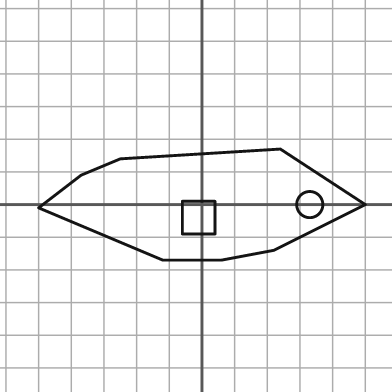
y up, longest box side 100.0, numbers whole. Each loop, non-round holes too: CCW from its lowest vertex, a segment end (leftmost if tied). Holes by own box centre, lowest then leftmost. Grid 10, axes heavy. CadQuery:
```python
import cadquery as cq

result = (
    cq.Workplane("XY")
    .moveTo(-12.0, -17.0)
    .lineTo(6.0, -17.0)
    .lineTo(22.0, -14.0)
    .lineTo(50.0, 0.0)
    .lineTo(24.0, 17.0)
    .lineTo(-25.0, 14.0)
    .lineTo(-37.0, 9.0)
    .lineTo(-50.0, -1.0)
    .close()
    .moveTo(-6.0, -9.0)
    .lineTo(4.0, -9.0)
    .lineTo(4.0, 1.0)
    .lineTo(-6.0, 1.0)
    .close()
    .moveTo(33.0, 0.0)
    .circle(4.0)
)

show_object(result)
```